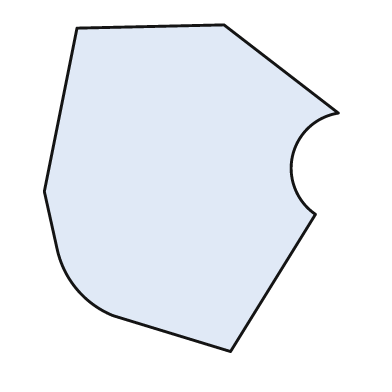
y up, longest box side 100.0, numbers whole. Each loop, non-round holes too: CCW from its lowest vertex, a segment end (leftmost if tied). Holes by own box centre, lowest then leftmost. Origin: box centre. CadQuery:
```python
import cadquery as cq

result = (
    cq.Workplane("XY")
    .moveTo(12.0, -50.0)
    .lineTo(38.0, -8.0)
    .threePointArc((31.0, 10.0), (45.0, 23.0))
    .lineTo(10.0, 50.0)
    .lineTo(-35.0, 49.0)
    .lineTo(-45.0, -1.0)
    .lineTo(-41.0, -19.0)
    .threePointArc((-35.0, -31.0), (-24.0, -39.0))
    .close()
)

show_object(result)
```